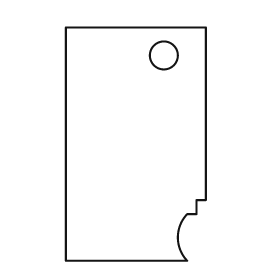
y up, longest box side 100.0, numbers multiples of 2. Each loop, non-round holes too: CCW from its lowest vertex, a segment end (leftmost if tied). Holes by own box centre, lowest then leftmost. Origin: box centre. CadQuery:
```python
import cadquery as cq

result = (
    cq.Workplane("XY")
    .moveTo(-30.0, -50.0)
    .lineTo(22.0, -50.0)
    .threePointArc((18.0, -40.0), (22.0, -30.0))
    .lineTo(26.0, -30.0)
    .lineTo(26.0, -24.0)
    .lineTo(30.0, -24.0)
    .lineTo(30.0, 50.0)
    .lineTo(-30.0, 50.0)
    .close()
    .moveTo(12.0, 38.0)
    .circle(6.0)
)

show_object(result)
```